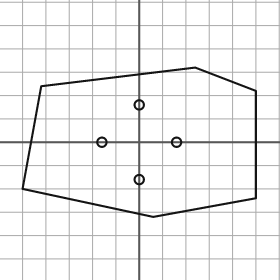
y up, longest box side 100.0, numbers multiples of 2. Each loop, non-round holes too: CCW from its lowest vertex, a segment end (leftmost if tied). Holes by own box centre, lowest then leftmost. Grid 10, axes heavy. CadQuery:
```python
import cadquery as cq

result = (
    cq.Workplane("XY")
    .moveTo(6.0, -32.0)
    .lineTo(50.0, -24.0)
    .lineTo(50.0, 22.0)
    .lineTo(24.0, 32.0)
    .lineTo(-42.0, 24.0)
    .lineTo(-50.0, -20.0)
    .close()
    .moveTo(0.0, -16.0)
    .circle(2.0)
    .moveTo(-16.0, 0.0)
    .circle(2.0)
    .moveTo(16.0, 0.0)
    .circle(2.0)
    .moveTo(0.0, 16.0)
    .circle(2.0)
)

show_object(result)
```